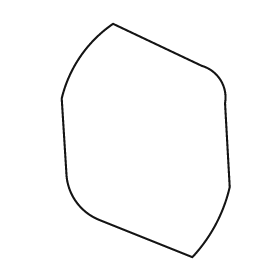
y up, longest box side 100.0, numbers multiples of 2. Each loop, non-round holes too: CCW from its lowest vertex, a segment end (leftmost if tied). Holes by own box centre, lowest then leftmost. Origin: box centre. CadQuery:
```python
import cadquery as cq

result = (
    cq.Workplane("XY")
    .moveTo(20.0, -50.0)
    .threePointArc((30.0, -36.0), (36.0, -20.0))
    .lineTo(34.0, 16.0)
    .threePointArc((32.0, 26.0), (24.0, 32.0))
    .lineTo(-14.0, 50.0)
    .threePointArc((-28.0, 36.0), (-36.0, 18.0))
    .lineTo(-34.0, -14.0)
    .threePointArc((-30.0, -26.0), (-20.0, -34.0))
    .close()
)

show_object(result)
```